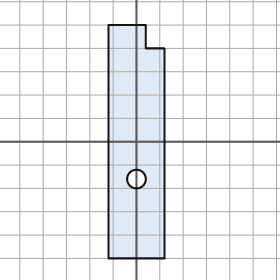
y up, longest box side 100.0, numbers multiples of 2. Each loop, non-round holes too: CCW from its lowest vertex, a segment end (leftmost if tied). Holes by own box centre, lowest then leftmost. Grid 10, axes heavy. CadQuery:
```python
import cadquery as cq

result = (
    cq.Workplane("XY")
    .moveTo(-12.0, -50.0)
    .lineTo(12.0, -50.0)
    .lineTo(12.0, 40.0)
    .lineTo(4.0, 40.0)
    .lineTo(4.0, 50.0)
    .lineTo(-12.0, 50.0)
    .close()
    .moveTo(0.0, -16.0)
    .circle(4.0)
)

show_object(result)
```